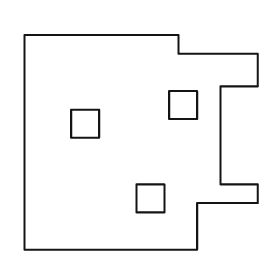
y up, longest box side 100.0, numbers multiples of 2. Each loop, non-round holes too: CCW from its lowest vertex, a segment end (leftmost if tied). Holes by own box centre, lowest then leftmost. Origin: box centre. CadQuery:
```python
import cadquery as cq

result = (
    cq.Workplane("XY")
    .moveTo(-50.0, -46.0)
    .lineTo(24.0, -46.0)
    .lineTo(24.0, -26.0)
    .lineTo(50.0, -26.0)
    .lineTo(50.0, -18.0)
    .lineTo(34.0, -18.0)
    .lineTo(34.0, 24.0)
    .lineTo(50.0, 24.0)
    .lineTo(50.0, 38.0)
    .lineTo(16.0, 38.0)
    .lineTo(16.0, 46.0)
    .lineTo(-50.0, 46.0)
    .close()
    .moveTo(-2.0, -30.0)
    .lineTo(10.0, -30.0)
    .lineTo(10.0, -18.0)
    .lineTo(-2.0, -18.0)
    .close()
    .moveTo(-30.0, 2.0)
    .lineTo(-18.0, 2.0)
    .lineTo(-18.0, 14.0)
    .lineTo(-30.0, 14.0)
    .close()
    .moveTo(12.0, 10.0)
    .lineTo(24.0, 10.0)
    .lineTo(24.0, 22.0)
    .lineTo(12.0, 22.0)
    .close()
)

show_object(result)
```